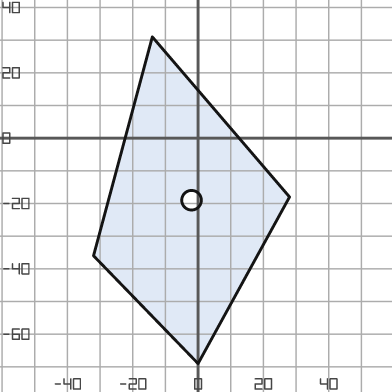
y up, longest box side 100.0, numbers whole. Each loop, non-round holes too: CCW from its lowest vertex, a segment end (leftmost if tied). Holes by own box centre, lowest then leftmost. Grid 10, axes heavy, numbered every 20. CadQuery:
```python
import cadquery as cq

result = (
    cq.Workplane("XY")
    .moveTo(0.0, -69.0)
    .lineTo(28.0, -18.0)
    .lineTo(-14.0, 31.0)
    .lineTo(-32.0, -36.0)
    .close()
    .moveTo(-2.0, -19.0)
    .circle(3.0)
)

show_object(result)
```